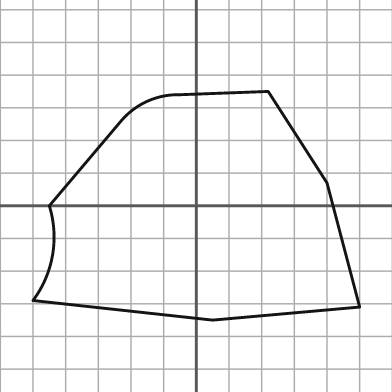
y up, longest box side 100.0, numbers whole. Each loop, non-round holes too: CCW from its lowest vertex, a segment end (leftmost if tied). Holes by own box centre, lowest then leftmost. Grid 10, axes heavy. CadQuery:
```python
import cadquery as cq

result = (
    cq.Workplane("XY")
    .moveTo(5.0, -35.0)
    .lineTo(50.0, -31.0)
    .lineTo(40.0, 7.0)
    .lineTo(22.0, 35.0)
    .lineTo(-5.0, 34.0)
    .threePointArc((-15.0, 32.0), (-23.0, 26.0))
    .lineTo(-45.0, 0.0)
    .threePointArc((-44.0, -15.0), (-50.0, -29.0))
    .close()
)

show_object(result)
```